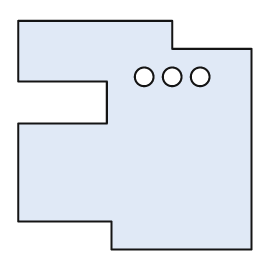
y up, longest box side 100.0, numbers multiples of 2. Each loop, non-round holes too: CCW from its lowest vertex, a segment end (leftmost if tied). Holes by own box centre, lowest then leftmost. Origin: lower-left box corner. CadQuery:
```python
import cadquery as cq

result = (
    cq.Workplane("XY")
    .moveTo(40.0, 0.0)
    .lineTo(100.0, 0.0)
    .lineTo(100.0, 86.0)
    .lineTo(66.0, 86.0)
    .lineTo(66.0, 98.0)
    .lineTo(0.0, 98.0)
    .lineTo(0.0, 72.0)
    .lineTo(38.0, 72.0)
    .lineTo(38.0, 54.0)
    .lineTo(0.0, 54.0)
    .lineTo(0.0, 12.0)
    .lineTo(40.0, 12.0)
    .close()
    .moveTo(54.0, 74.0)
    .circle(4.0)
    .moveTo(66.0, 74.0)
    .circle(4.0)
    .moveTo(78.0, 74.0)
    .circle(4.0)
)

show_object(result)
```